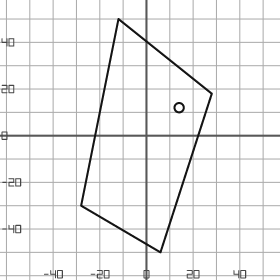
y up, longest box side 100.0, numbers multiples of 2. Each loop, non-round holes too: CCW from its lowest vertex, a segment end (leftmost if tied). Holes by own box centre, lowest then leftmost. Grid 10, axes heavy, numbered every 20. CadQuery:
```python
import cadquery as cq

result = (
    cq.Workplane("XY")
    .moveTo(6.0, -50.0)
    .lineTo(28.0, 18.0)
    .lineTo(-12.0, 50.0)
    .lineTo(-28.0, -30.0)
    .close()
    .moveTo(14.0, 12.0)
    .circle(2.0)
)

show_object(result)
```